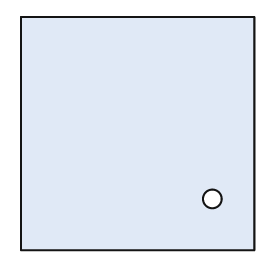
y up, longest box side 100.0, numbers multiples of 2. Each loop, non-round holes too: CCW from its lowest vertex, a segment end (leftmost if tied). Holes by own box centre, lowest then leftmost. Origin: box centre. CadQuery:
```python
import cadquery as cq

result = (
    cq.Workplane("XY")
    .moveTo(-50.0, -50.0)
    .lineTo(50.0, -50.0)
    .lineTo(50.0, 50.0)
    .lineTo(-50.0, 50.0)
    .close()
    .moveTo(32.0, -28.0)
    .circle(4.0)
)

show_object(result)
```